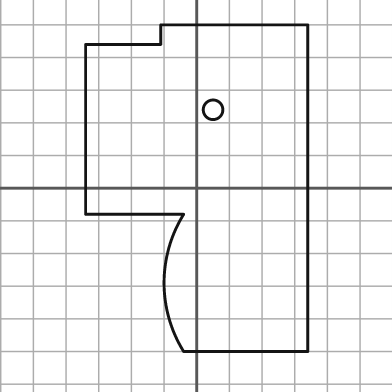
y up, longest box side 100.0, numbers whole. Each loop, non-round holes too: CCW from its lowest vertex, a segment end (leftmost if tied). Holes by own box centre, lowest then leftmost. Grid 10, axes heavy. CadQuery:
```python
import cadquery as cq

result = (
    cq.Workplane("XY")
    .moveTo(-4.0, -50.0)
    .lineTo(34.0, -50.0)
    .lineTo(34.0, 50.0)
    .lineTo(-11.0, 50.0)
    .lineTo(-11.0, 44.0)
    .lineTo(-34.0, 44.0)
    .lineTo(-34.0, -8.0)
    .lineTo(-4.0, -8.0)
    .threePointArc((-10.0, -29.0), (-4.0, -50.0))
    .close()
    .moveTo(5.0, 24.0)
    .circle(3.0)
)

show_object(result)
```